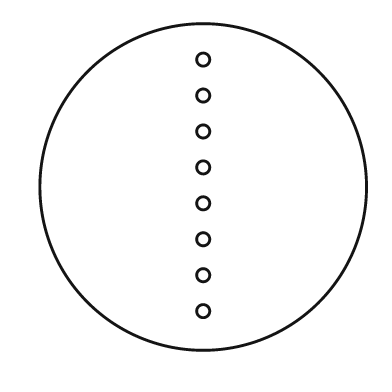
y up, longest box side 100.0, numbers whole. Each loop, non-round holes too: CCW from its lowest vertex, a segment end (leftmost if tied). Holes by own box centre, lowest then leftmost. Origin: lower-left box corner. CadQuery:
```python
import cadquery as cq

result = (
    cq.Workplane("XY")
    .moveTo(50.0, 50.0)
    .circle(50.0)
    .moveTo(50.0, 12.0)
    .circle(2.0)
    .moveTo(50.0, 23.0)
    .circle(2.0)
    .moveTo(50.0, 34.0)
    .circle(2.0)
    .moveTo(50.0, 45.0)
    .circle(2.0)
    .moveTo(50.0, 56.0)
    .circle(2.0)
    .moveTo(50.0, 67.0)
    .circle(2.0)
    .moveTo(50.0, 78.0)
    .circle(2.0)
    .moveTo(50.0, 89.0)
    .circle(2.0)
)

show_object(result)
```